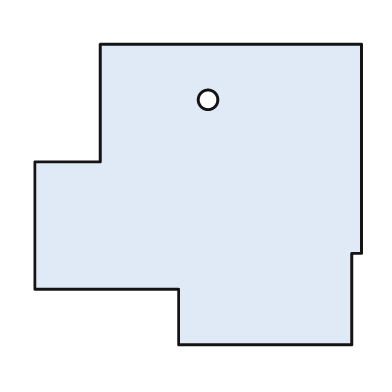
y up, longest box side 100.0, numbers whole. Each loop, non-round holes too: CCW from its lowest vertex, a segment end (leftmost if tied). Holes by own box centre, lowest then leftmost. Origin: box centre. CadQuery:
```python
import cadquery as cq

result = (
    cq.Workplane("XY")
    .moveTo(-6.0, -46.0)
    .lineTo(47.0, -46.0)
    .lineTo(47.0, -18.0)
    .lineTo(50.0, -18.0)
    .lineTo(50.0, 46.0)
    .lineTo(-30.0, 46.0)
    .lineTo(-30.0, 10.0)
    .lineTo(-50.0, 10.0)
    .lineTo(-50.0, -29.0)
    .lineTo(-6.0, -29.0)
    .close()
    .moveTo(3.0, 29.0)
    .circle(3.0)
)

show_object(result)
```